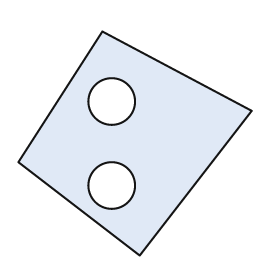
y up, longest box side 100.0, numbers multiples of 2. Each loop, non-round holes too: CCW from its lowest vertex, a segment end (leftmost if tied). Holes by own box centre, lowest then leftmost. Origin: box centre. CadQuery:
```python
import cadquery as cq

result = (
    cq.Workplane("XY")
    .moveTo(2.0, -48.0)
    .lineTo(50.0, 14.0)
    .lineTo(-14.0, 48.0)
    .lineTo(-50.0, -8.0)
    .close()
    .moveTo(-10.0, -18.0)
    .circle(10.0)
    .moveTo(-10.0, 18.0)
    .circle(10.0)
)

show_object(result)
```